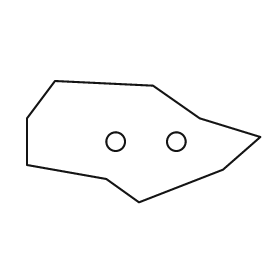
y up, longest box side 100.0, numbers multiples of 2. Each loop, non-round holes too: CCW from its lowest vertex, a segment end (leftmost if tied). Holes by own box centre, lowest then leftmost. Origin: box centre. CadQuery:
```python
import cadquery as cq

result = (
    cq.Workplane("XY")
    .moveTo(-2.0, -26.0)
    .lineTo(34.0, -12.0)
    .lineTo(50.0, 2.0)
    .lineTo(24.0, 10.0)
    .lineTo(4.0, 24.0)
    .lineTo(-38.0, 26.0)
    .lineTo(-50.0, 10.0)
    .lineTo(-50.0, -10.0)
    .lineTo(-16.0, -16.0)
    .close()
    .moveTo(-12.0, 0.0)
    .circle(4.0)
    .moveTo(14.0, 0.0)
    .circle(4.0)
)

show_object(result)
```